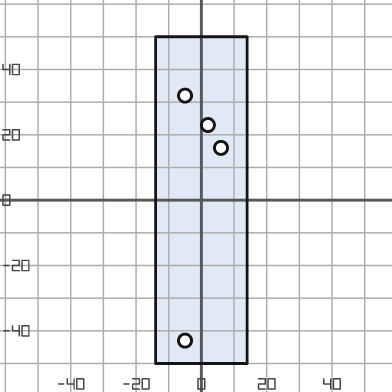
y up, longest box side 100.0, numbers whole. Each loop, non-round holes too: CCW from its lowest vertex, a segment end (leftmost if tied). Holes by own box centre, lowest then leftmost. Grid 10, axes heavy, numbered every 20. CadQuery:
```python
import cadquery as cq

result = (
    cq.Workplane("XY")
    .moveTo(-14.0, -50.0)
    .lineTo(14.0, -50.0)
    .lineTo(14.0, 50.0)
    .lineTo(-14.0, 50.0)
    .close()
    .moveTo(-5.0, -43.0)
    .circle(2.0)
    .moveTo(6.0, 16.0)
    .circle(2.0)
    .moveTo(2.0, 23.0)
    .circle(2.0)
    .moveTo(-5.0, 32.0)
    .circle(2.0)
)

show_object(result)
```